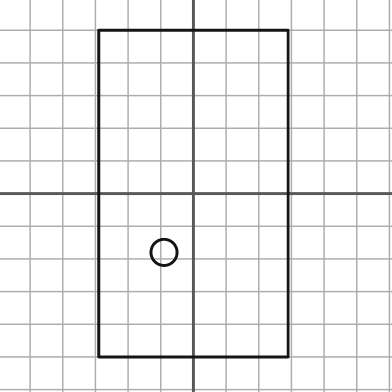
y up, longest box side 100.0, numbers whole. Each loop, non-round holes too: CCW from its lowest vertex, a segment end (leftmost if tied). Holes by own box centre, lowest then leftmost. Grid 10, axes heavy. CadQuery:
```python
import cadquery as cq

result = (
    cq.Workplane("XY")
    .moveTo(-29.0, -50.0)
    .lineTo(29.0, -50.0)
    .lineTo(29.0, 50.0)
    .lineTo(-29.0, 50.0)
    .close()
    .moveTo(-9.0, -18.0)
    .circle(4.0)
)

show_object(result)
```